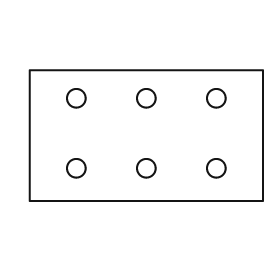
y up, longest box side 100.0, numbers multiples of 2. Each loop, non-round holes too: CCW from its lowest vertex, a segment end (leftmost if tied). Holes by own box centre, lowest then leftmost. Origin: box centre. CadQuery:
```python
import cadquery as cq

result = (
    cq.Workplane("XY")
    .moveTo(-50.0, -28.0)
    .lineTo(50.0, -28.0)
    .lineTo(50.0, 28.0)
    .lineTo(-50.0, 28.0)
    .close()
    .moveTo(-30.0, -14.0)
    .circle(4.0)
    .moveTo(0.0, -14.0)
    .circle(4.0)
    .moveTo(30.0, -14.0)
    .circle(4.0)
    .moveTo(-30.0, 16.0)
    .circle(4.0)
    .moveTo(0.0, 16.0)
    .circle(4.0)
    .moveTo(30.0, 16.0)
    .circle(4.0)
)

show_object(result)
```